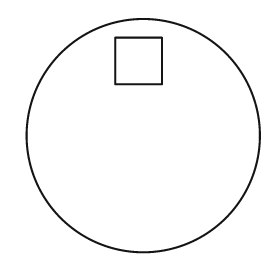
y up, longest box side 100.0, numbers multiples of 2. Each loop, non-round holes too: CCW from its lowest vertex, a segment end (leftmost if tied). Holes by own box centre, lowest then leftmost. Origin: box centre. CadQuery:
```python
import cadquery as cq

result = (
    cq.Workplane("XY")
    .moveTo(0.0, 0.0)
    .circle(50.0)
    .moveTo(-12.0, 22.0)
    .lineTo(8.0, 22.0)
    .lineTo(8.0, 42.0)
    .lineTo(-12.0, 42.0)
    .close()
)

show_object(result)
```